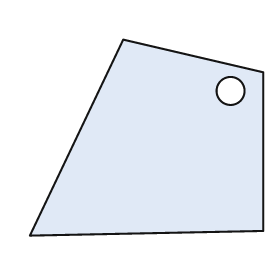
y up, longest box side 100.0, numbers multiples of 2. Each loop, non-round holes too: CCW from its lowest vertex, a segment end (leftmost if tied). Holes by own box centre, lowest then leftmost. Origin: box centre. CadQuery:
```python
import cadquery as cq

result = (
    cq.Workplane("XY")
    .moveTo(-50.0, -42.0)
    .lineTo(50.0, -40.0)
    .lineTo(50.0, 28.0)
    .lineTo(-10.0, 42.0)
    .close()
    .moveTo(36.0, 20.0)
    .circle(6.0)
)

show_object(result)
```